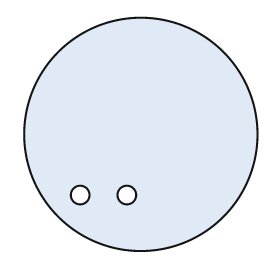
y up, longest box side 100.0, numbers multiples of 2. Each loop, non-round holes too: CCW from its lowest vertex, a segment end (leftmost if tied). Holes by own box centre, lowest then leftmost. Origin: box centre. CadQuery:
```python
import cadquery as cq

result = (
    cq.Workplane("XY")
    .moveTo(0.0, 0.0)
    .circle(50.0)
    .moveTo(-26.0, -26.0)
    .circle(4.0)
    .moveTo(-6.0, -26.0)
    .circle(4.0)
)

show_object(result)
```